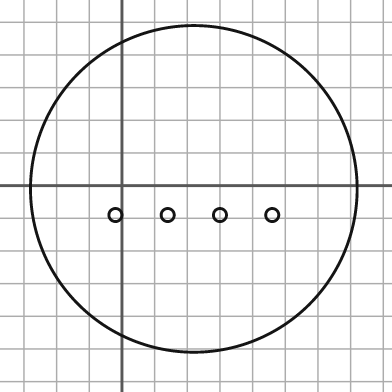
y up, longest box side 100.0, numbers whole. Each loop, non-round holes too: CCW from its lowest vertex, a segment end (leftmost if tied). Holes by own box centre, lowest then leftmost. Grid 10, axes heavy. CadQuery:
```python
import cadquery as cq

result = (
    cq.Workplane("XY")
    .moveTo(22.0, -1.0)
    .circle(50.0)
    .moveTo(-2.0, -9.0)
    .circle(2.0)
    .moveTo(14.0, -9.0)
    .circle(2.0)
    .moveTo(30.0, -9.0)
    .circle(2.0)
    .moveTo(46.0, -9.0)
    .circle(2.0)
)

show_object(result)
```